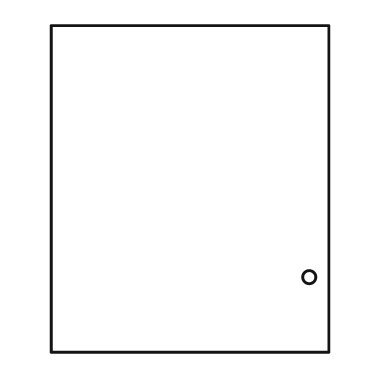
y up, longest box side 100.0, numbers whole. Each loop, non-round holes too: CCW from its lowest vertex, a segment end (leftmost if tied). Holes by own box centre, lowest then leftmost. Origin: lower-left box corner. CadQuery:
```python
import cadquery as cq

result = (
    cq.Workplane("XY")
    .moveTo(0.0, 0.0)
    .lineTo(85.0, 0.0)
    .lineTo(85.0, 100.0)
    .lineTo(0.0, 100.0)
    .close()
    .moveTo(79.0, 23.0)
    .circle(2.0)
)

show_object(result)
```